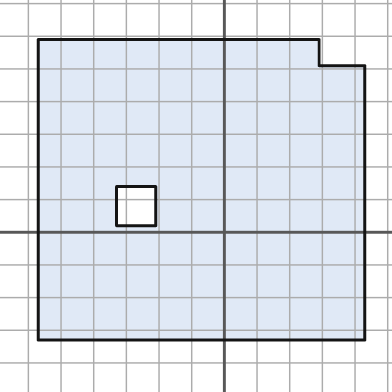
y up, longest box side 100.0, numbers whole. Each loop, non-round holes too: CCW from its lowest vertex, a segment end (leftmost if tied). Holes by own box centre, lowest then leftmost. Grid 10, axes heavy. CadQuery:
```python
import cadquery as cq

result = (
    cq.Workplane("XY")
    .moveTo(-57.0, -33.0)
    .lineTo(43.0, -33.0)
    .lineTo(43.0, 51.0)
    .lineTo(29.0, 51.0)
    .lineTo(29.0, 59.0)
    .lineTo(-57.0, 59.0)
    .close()
    .moveTo(-33.0, 2.0)
    .lineTo(-21.0, 2.0)
    .lineTo(-21.0, 14.0)
    .lineTo(-33.0, 14.0)
    .close()
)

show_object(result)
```